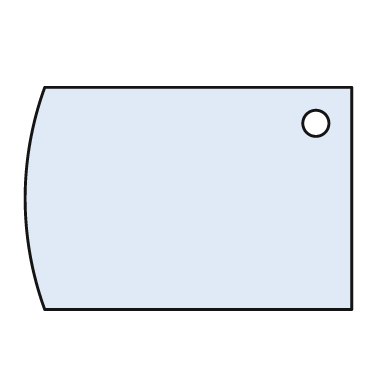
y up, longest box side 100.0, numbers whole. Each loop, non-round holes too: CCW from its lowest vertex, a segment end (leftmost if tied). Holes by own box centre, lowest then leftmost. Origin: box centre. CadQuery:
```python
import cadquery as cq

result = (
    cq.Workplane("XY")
    .moveTo(-44.0, -34.0)
    .lineTo(50.0, -34.0)
    .lineTo(50.0, 34.0)
    .lineTo(-44.0, 34.0)
    .threePointArc((-50.0, 0.0), (-44.0, -34.0))
    .close()
    .moveTo(39.0, 23.0)
    .circle(4.0)
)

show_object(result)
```